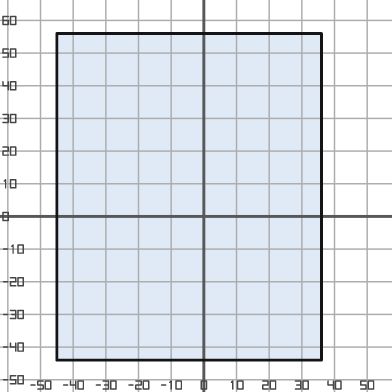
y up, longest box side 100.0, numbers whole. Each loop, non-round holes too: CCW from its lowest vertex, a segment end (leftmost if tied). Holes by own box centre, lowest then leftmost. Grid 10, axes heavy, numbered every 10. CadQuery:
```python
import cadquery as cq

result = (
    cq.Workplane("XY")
    .moveTo(-45.0, -44.0)
    .lineTo(36.0, -44.0)
    .lineTo(36.0, 56.0)
    .lineTo(-45.0, 56.0)
    .close()
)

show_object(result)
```